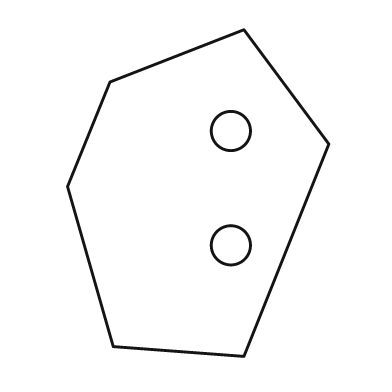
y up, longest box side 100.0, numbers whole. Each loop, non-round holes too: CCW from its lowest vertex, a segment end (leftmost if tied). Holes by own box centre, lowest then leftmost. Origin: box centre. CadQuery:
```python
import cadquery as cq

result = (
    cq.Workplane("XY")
    .moveTo(14.0, -50.0)
    .lineTo(40.0, 15.0)
    .lineTo(14.0, 50.0)
    .lineTo(-27.0, 34.0)
    .lineTo(-40.0, 2.0)
    .lineTo(-26.0, -47.0)
    .close()
    .moveTo(10.0, -16.0)
    .circle(6.0)
    .moveTo(10.0, 19.0)
    .circle(6.0)
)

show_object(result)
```